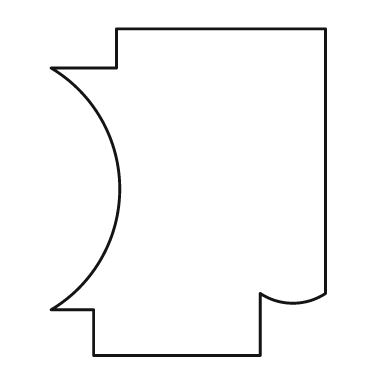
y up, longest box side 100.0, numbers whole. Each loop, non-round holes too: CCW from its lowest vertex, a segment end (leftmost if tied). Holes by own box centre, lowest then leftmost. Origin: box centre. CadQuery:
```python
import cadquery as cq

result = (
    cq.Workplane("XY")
    .moveTo(-29.0, -50.0)
    .lineTo(22.0, -50.0)
    .lineTo(22.0, -31.0)
    .threePointArc((32.0, -34.0), (42.0, -31.0))
    .lineTo(42.0, 50.0)
    .lineTo(-22.0, 50.0)
    .lineTo(-22.0, 38.0)
    .lineTo(-42.0, 38.0)
    .threePointArc((-21.0, 1.0), (-42.0, -36.0))
    .lineTo(-29.0, -36.0)
    .close()
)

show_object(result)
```